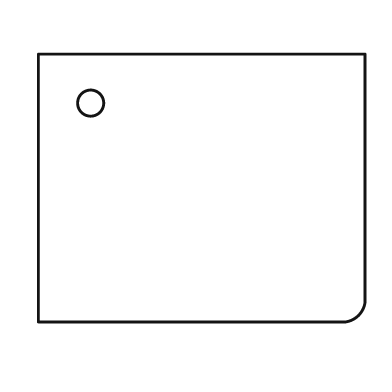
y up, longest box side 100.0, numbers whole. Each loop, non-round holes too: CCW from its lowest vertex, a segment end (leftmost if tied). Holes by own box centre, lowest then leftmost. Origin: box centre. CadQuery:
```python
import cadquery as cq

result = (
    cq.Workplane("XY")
    .moveTo(-50.0, -41.0)
    .lineTo(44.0, -41.0)
    .threePointArc((48.0, -39.0), (50.0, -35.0))
    .lineTo(50.0, 41.0)
    .lineTo(-50.0, 41.0)
    .close()
    .moveTo(-34.0, 26.0)
    .circle(4.0)
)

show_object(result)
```